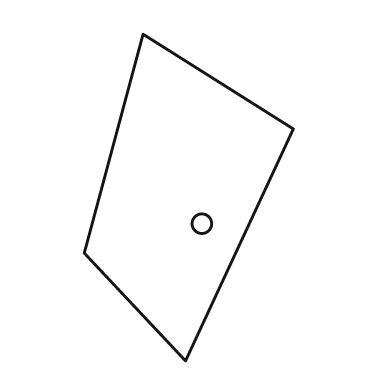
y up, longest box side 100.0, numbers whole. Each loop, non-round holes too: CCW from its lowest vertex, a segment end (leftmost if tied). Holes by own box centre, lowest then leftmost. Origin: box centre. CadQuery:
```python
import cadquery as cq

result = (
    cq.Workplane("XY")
    .moveTo(-1.0, -50.0)
    .lineTo(32.0, 21.0)
    .lineTo(-14.0, 50.0)
    .lineTo(-32.0, -17.0)
    .close()
    .moveTo(4.0, -8.0)
    .circle(3.0)
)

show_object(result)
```